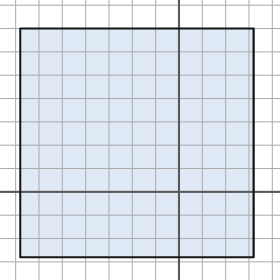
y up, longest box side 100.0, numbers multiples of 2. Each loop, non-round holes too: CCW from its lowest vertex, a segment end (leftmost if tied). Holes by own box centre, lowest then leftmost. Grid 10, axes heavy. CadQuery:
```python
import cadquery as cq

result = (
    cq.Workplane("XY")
    .moveTo(-68.0, -28.0)
    .lineTo(32.0, -28.0)
    .lineTo(32.0, 70.0)
    .lineTo(-68.0, 70.0)
    .close()
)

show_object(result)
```